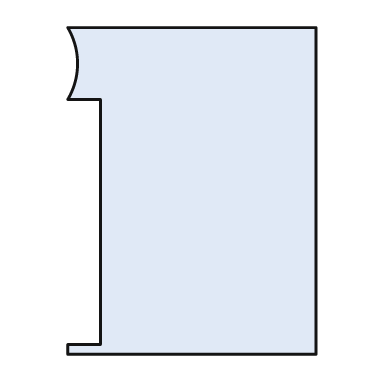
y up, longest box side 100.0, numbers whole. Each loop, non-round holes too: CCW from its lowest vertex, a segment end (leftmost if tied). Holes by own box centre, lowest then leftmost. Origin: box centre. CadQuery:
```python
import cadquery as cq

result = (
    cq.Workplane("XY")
    .moveTo(-38.0, -50.0)
    .lineTo(38.0, -50.0)
    .lineTo(38.0, 50.0)
    .lineTo(-38.0, 50.0)
    .threePointArc((-35.0, 39.0), (-38.0, 28.0))
    .lineTo(-28.0, 28.0)
    .lineTo(-28.0, -47.0)
    .lineTo(-38.0, -47.0)
    .close()
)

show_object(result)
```